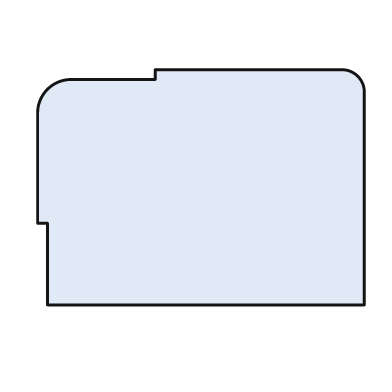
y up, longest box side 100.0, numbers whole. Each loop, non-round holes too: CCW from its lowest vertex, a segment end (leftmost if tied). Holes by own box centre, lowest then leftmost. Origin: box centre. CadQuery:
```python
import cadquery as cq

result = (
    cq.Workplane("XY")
    .moveTo(-47.0, -36.0)
    .lineTo(50.0, -36.0)
    .lineTo(50.0, 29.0)
    .threePointArc((48.0, 34.0), (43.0, 36.0))
    .lineTo(-14.0, 36.0)
    .lineTo(-14.0, 33.0)
    .lineTo(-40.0, 33.0)
    .threePointArc((-47.0, 30.0), (-50.0, 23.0))
    .lineTo(-50.0, -11.0)
    .lineTo(-47.0, -11.0)
    .close()
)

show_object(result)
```